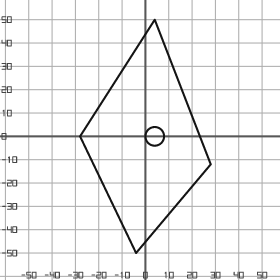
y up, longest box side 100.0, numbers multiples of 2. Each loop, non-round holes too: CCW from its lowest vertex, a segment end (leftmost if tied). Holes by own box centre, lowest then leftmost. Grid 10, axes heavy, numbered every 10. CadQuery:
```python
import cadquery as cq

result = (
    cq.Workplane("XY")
    .moveTo(-4.0, -50.0)
    .lineTo(28.0, -12.0)
    .lineTo(4.0, 50.0)
    .lineTo(-28.0, 0.0)
    .close()
    .moveTo(4.0, 0.0)
    .circle(4.0)
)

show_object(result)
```